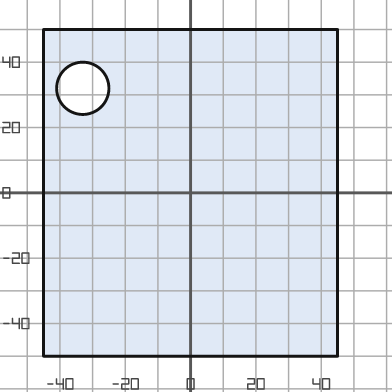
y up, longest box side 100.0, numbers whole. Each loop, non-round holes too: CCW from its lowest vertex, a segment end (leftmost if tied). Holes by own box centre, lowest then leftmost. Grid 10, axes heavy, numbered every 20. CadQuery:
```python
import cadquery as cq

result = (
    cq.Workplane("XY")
    .moveTo(-45.0, -50.0)
    .lineTo(45.0, -50.0)
    .lineTo(45.0, 50.0)
    .lineTo(-45.0, 50.0)
    .close()
    .moveTo(-33.0, 32.0)
    .circle(8.0)
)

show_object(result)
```